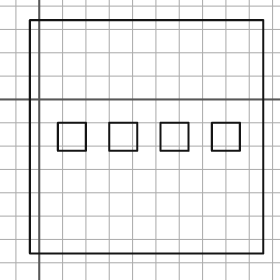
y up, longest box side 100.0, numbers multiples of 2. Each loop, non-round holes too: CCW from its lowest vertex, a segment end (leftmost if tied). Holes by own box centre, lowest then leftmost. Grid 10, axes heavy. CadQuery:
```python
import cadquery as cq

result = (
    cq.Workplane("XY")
    .moveTo(-4.0, -66.0)
    .lineTo(96.0, -66.0)
    .lineTo(96.0, 34.0)
    .lineTo(-4.0, 34.0)
    .close()
    .moveTo(8.0, -22.0)
    .lineTo(20.0, -22.0)
    .lineTo(20.0, -10.0)
    .lineTo(8.0, -10.0)
    .close()
    .moveTo(30.0, -22.0)
    .lineTo(42.0, -22.0)
    .lineTo(42.0, -10.0)
    .lineTo(30.0, -10.0)
    .close()
    .moveTo(52.0, -22.0)
    .lineTo(64.0, -22.0)
    .lineTo(64.0, -10.0)
    .lineTo(52.0, -10.0)
    .close()
    .moveTo(74.0, -22.0)
    .lineTo(86.0, -22.0)
    .lineTo(86.0, -10.0)
    .lineTo(74.0, -10.0)
    .close()
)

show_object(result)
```